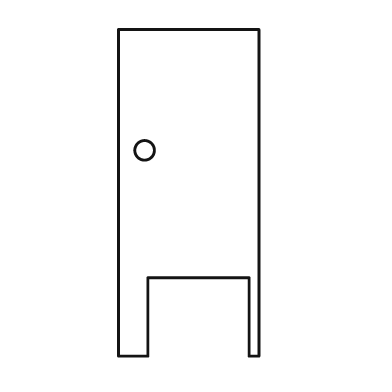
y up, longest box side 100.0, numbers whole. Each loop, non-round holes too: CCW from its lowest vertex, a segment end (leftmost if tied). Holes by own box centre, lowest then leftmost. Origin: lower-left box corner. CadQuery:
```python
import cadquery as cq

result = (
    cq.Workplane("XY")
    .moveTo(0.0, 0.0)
    .lineTo(9.0, 0.0)
    .lineTo(9.0, 24.0)
    .lineTo(40.0, 24.0)
    .lineTo(40.0, 0.0)
    .lineTo(43.0, 0.0)
    .lineTo(43.0, 100.0)
    .lineTo(0.0, 100.0)
    .close()
    .moveTo(8.0, 63.0)
    .circle(3.0)
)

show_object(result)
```